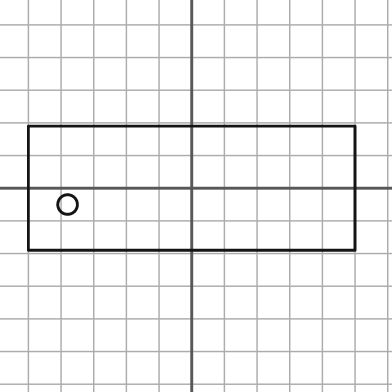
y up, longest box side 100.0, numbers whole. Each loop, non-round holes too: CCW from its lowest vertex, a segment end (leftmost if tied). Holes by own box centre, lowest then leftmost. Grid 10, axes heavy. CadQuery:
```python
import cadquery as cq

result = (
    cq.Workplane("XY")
    .moveTo(-50.0, -19.0)
    .lineTo(50.0, -19.0)
    .lineTo(50.0, 19.0)
    .lineTo(-50.0, 19.0)
    .close()
    .moveTo(-38.0, -5.0)
    .circle(3.0)
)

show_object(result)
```